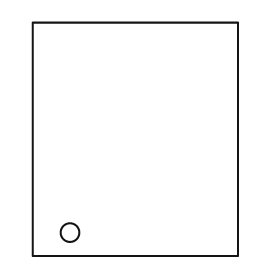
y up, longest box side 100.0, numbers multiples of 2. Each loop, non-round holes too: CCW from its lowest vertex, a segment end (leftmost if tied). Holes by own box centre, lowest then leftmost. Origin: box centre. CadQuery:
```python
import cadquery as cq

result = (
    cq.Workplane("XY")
    .moveTo(-44.0, -50.0)
    .lineTo(44.0, -50.0)
    .lineTo(44.0, 50.0)
    .lineTo(-44.0, 50.0)
    .close()
    .moveTo(-28.0, -40.0)
    .circle(4.0)
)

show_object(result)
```